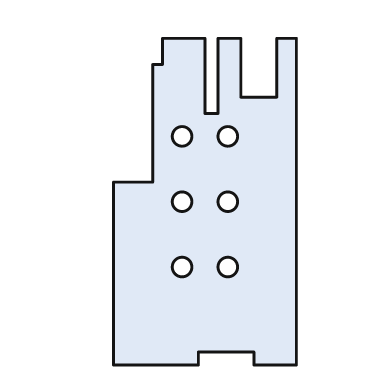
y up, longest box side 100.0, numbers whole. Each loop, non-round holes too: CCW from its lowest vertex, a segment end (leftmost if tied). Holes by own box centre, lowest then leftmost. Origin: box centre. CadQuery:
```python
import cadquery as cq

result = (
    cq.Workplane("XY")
    .moveTo(-28.0, -50.0)
    .lineTo(-2.0, -50.0)
    .lineTo(-2.0, -46.0)
    .lineTo(15.0, -46.0)
    .lineTo(15.0, -50.0)
    .lineTo(28.0, -50.0)
    .lineTo(28.0, 50.0)
    .lineTo(22.0, 50.0)
    .lineTo(22.0, 32.0)
    .lineTo(11.0, 32.0)
    .lineTo(11.0, 50.0)
    .lineTo(4.0, 50.0)
    .lineTo(4.0, 27.0)
    .lineTo(0.0, 27.0)
    .lineTo(0.0, 50.0)
    .lineTo(-13.0, 50.0)
    .lineTo(-13.0, 42.0)
    .lineTo(-16.0, 42.0)
    .lineTo(-16.0, 6.0)
    .lineTo(-28.0, 6.0)
    .close()
    .moveTo(-7.0, -20.0)
    .circle(3.0)
    .moveTo(7.0, -20.0)
    .circle(3.0)
    .moveTo(-7.0, 0.0)
    .circle(3.0)
    .moveTo(7.0, 0.0)
    .circle(3.0)
    .moveTo(-7.0, 20.0)
    .circle(3.0)
    .moveTo(7.0, 20.0)
    .circle(3.0)
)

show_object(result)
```